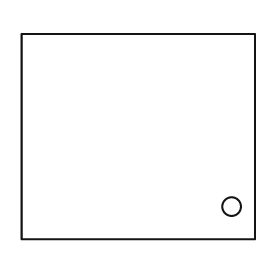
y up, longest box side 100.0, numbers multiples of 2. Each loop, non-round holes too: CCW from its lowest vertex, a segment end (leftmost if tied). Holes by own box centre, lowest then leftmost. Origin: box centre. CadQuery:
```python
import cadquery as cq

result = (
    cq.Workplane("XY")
    .moveTo(-50.0, -44.0)
    .lineTo(50.0, -44.0)
    .lineTo(50.0, 44.0)
    .lineTo(-50.0, 44.0)
    .close()
    .moveTo(40.0, -30.0)
    .circle(4.0)
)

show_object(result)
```